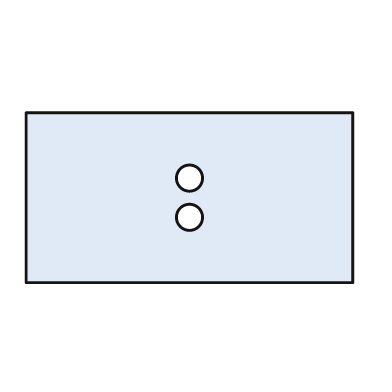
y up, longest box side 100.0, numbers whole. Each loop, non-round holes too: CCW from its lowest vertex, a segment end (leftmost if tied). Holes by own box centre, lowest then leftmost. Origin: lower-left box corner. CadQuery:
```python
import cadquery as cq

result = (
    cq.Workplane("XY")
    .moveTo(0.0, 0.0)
    .lineTo(100.0, 0.0)
    .lineTo(100.0, 52.0)
    .lineTo(0.0, 52.0)
    .close()
    .moveTo(50.0, 20.0)
    .circle(4.0)
    .moveTo(50.0, 32.0)
    .circle(4.0)
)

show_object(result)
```